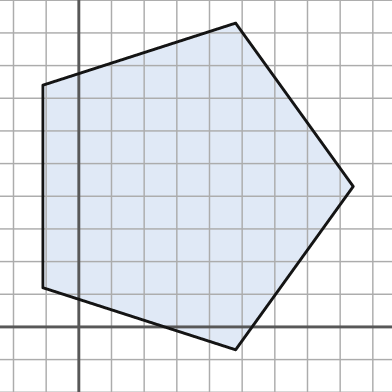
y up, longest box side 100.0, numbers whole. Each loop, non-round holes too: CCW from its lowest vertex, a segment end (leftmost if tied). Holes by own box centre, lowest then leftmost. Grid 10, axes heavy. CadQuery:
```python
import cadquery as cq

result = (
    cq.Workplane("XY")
    .moveTo(48.0, -7.0)
    .lineTo(84.0, 43.0)
    .lineTo(48.0, 93.0)
    .lineTo(-11.0, 74.0)
    .lineTo(-11.0, 12.0)
    .close()
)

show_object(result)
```